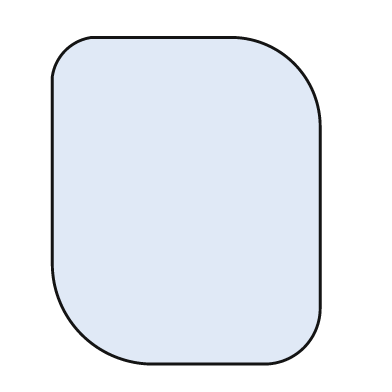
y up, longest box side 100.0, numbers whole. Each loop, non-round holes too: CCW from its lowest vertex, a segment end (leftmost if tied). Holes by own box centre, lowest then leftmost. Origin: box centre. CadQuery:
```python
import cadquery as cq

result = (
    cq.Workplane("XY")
    .moveTo(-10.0, -50.0)
    .lineTo(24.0, -50.0)
    .threePointArc((36.0, -45.0), (41.0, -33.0))
    .lineTo(41.0, 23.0)
    .threePointArc((33.0, 42.0), (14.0, 50.0))
    .lineTo(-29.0, 50.0)
    .threePointArc((-37.0, 46.0), (-41.0, 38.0))
    .lineTo(-41.0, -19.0)
    .threePointArc((-32.0, -41.0), (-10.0, -50.0))
    .close()
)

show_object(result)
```